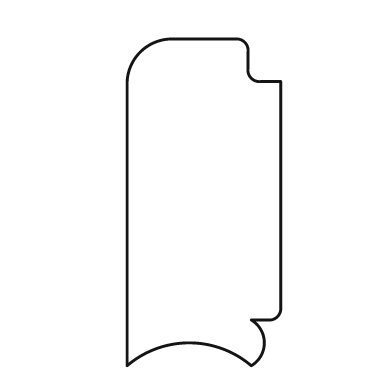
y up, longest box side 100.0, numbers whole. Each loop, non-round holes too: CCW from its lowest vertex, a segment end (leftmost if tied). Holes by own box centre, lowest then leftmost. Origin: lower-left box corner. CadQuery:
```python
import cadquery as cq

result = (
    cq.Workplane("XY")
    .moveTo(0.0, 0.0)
    .threePointArc((19.0, 7.0), (38.0, 0.0))
    .threePointArc((42.0, 7.0), (38.0, 14.0))
    .lineTo(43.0, 14.0)
    .threePointArc((46.0, 15.0), (47.0, 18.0))
    .lineTo(47.0, 87.0)
    .lineTo(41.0, 87.0)
    .threePointArc((38.0, 88.0), (37.0, 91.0))
    .lineTo(37.0, 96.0)
    .threePointArc((36.0, 99.0), (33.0, 100.0))
    .lineTo(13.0, 100.0)
    .threePointArc((4.0, 96.0), (0.0, 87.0))
    .close()
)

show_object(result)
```